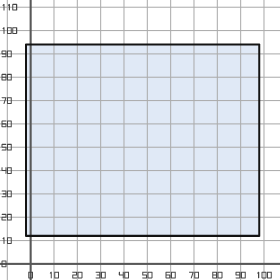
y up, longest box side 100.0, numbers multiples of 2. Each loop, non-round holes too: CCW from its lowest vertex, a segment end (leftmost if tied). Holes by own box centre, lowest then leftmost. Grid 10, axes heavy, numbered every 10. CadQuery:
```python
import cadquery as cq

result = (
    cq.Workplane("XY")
    .moveTo(-2.0, 12.0)
    .lineTo(98.0, 12.0)
    .lineTo(98.0, 94.0)
    .lineTo(-2.0, 94.0)
    .close()
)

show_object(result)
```